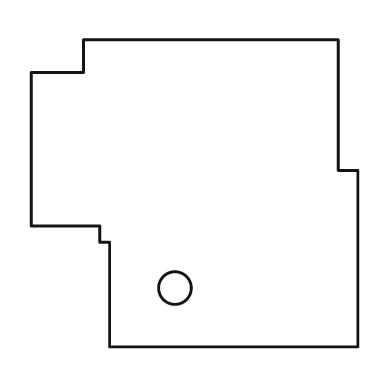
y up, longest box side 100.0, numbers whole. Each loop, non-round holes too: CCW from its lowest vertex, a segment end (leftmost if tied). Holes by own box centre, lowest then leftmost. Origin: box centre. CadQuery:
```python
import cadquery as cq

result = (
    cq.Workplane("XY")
    .moveTo(-26.0, -47.0)
    .lineTo(50.0, -47.0)
    .lineTo(50.0, 7.0)
    .lineTo(44.0, 7.0)
    .lineTo(44.0, 47.0)
    .lineTo(-34.0, 47.0)
    .lineTo(-34.0, 37.0)
    .lineTo(-50.0, 37.0)
    .lineTo(-50.0, -10.0)
    .lineTo(-29.0, -10.0)
    .lineTo(-29.0, -15.0)
    .lineTo(-26.0, -15.0)
    .close()
    .moveTo(-6.0, -29.0)
    .circle(5.0)
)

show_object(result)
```